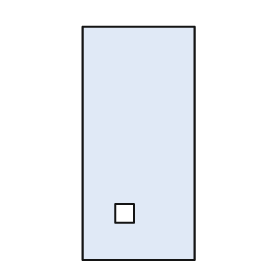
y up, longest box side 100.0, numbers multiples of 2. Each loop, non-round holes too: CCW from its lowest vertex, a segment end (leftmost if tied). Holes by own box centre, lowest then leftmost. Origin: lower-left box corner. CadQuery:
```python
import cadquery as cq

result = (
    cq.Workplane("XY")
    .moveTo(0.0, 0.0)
    .lineTo(48.0, 0.0)
    .lineTo(48.0, 100.0)
    .lineTo(0.0, 100.0)
    .close()
    .moveTo(14.0, 16.0)
    .lineTo(22.0, 16.0)
    .lineTo(22.0, 24.0)
    .lineTo(14.0, 24.0)
    .close()
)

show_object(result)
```